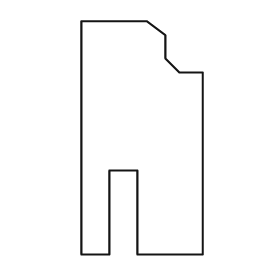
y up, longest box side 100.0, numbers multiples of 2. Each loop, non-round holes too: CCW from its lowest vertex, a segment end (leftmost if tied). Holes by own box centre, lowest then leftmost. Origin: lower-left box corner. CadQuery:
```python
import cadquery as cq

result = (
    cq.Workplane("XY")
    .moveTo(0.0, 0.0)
    .lineTo(12.0, 0.0)
    .lineTo(12.0, 36.0)
    .lineTo(24.0, 36.0)
    .lineTo(24.0, 0.0)
    .lineTo(52.0, 0.0)
    .lineTo(52.0, 78.0)
    .lineTo(42.0, 78.0)
    .lineTo(36.0, 84.0)
    .lineTo(36.0, 94.0)
    .lineTo(28.0, 100.0)
    .lineTo(0.0, 100.0)
    .close()
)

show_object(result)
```